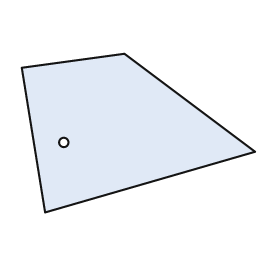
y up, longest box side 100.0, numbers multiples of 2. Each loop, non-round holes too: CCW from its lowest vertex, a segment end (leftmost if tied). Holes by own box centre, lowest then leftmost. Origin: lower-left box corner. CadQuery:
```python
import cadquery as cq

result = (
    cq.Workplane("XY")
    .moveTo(10.0, 0.0)
    .lineTo(100.0, 26.0)
    .lineTo(44.0, 68.0)
    .lineTo(0.0, 62.0)
    .close()
    .moveTo(18.0, 30.0)
    .circle(2.0)
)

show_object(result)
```